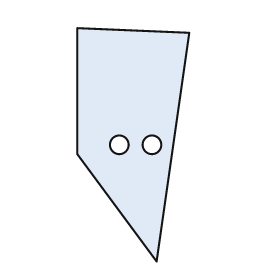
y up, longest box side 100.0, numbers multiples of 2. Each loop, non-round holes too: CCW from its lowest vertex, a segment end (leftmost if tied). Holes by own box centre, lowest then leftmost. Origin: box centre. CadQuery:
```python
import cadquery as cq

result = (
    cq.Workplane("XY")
    .moveTo(10.0, -50.0)
    .lineTo(24.0, 48.0)
    .lineTo(-24.0, 50.0)
    .lineTo(-24.0, -4.0)
    .close()
    .moveTo(-6.0, 0.0)
    .circle(4.0)
    .moveTo(8.0, 0.0)
    .circle(4.0)
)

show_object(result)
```